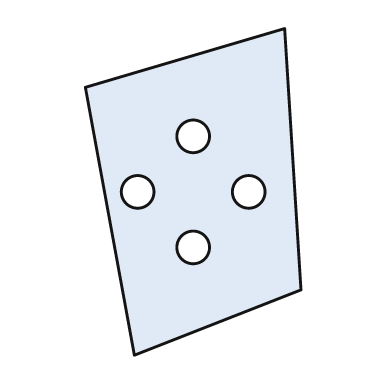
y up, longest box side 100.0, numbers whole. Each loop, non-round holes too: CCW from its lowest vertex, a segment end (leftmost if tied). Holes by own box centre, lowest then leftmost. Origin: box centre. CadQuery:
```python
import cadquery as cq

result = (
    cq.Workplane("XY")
    .moveTo(-18.0, -50.0)
    .lineTo(33.0, -30.0)
    .lineTo(28.0, 50.0)
    .lineTo(-33.0, 32.0)
    .close()
    .moveTo(0.0, -17.0)
    .circle(5.0)
    .moveTo(-17.0, 0.0)
    .circle(5.0)
    .moveTo(17.0, 0.0)
    .circle(5.0)
    .moveTo(0.0, 17.0)
    .circle(5.0)
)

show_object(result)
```